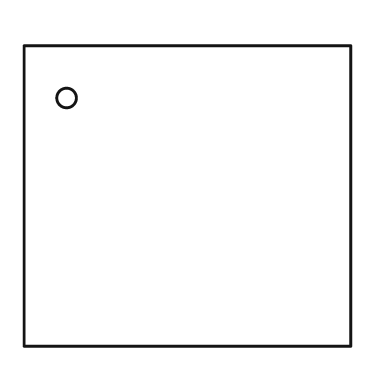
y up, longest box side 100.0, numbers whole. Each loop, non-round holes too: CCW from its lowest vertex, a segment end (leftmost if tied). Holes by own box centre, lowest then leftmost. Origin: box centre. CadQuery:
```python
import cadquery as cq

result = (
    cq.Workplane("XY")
    .moveTo(-50.0, -46.0)
    .lineTo(50.0, -46.0)
    .lineTo(50.0, 46.0)
    .lineTo(-50.0, 46.0)
    .close()
    .moveTo(-37.0, 30.0)
    .circle(3.0)
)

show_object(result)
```